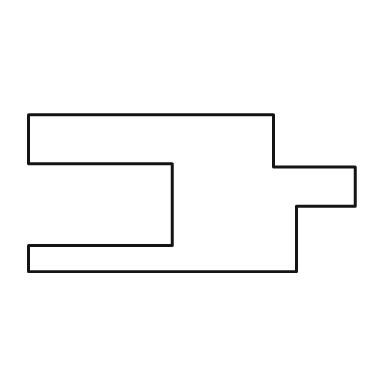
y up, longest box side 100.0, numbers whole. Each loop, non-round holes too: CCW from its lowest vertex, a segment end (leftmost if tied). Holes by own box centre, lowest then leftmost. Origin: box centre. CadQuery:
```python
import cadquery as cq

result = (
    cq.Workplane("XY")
    .moveTo(-50.0, -24.0)
    .lineTo(32.0, -24.0)
    .lineTo(32.0, -4.0)
    .lineTo(50.0, -4.0)
    .lineTo(50.0, 8.0)
    .lineTo(25.0, 8.0)
    .lineTo(25.0, 24.0)
    .lineTo(-50.0, 24.0)
    .lineTo(-50.0, 9.0)
    .lineTo(-6.0, 9.0)
    .lineTo(-6.0, -16.0)
    .lineTo(-50.0, -16.0)
    .close()
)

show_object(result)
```